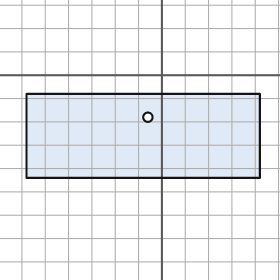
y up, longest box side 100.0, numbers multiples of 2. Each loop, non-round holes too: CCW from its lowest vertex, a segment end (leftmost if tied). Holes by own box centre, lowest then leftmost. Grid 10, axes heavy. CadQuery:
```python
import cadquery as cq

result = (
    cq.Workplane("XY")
    .moveTo(-58.0, -44.0)
    .lineTo(42.0, -44.0)
    .lineTo(42.0, -8.0)
    .lineTo(-58.0, -8.0)
    .close()
    .moveTo(-6.0, -18.0)
    .circle(2.0)
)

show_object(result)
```